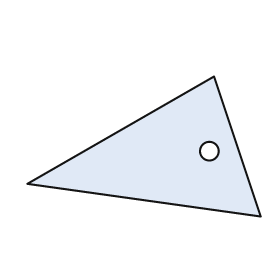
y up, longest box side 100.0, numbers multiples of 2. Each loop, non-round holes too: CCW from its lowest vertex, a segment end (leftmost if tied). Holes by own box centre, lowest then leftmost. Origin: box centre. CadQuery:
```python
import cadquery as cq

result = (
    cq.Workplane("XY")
    .moveTo(50.0, -30.0)
    .lineTo(30.0, 30.0)
    .lineTo(-50.0, -16.0)
    .close()
    .moveTo(28.0, -2.0)
    .circle(4.0)
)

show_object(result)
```